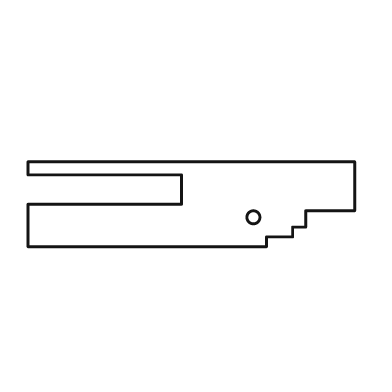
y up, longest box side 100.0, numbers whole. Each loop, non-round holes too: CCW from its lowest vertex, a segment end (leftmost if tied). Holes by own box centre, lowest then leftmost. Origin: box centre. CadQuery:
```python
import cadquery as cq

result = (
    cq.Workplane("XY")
    .moveTo(-50.0, -13.0)
    .lineTo(23.0, -13.0)
    .lineTo(23.0, -10.0)
    .lineTo(31.0, -10.0)
    .lineTo(31.0, -7.0)
    .lineTo(35.0, -7.0)
    .lineTo(35.0, -2.0)
    .lineTo(50.0, -2.0)
    .lineTo(50.0, 13.0)
    .lineTo(-50.0, 13.0)
    .lineTo(-50.0, 9.0)
    .lineTo(-3.0, 9.0)
    .lineTo(-3.0, 0.0)
    .lineTo(-50.0, 0.0)
    .close()
    .moveTo(19.0, -4.0)
    .circle(2.0)
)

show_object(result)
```